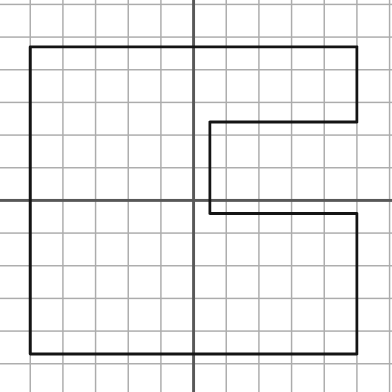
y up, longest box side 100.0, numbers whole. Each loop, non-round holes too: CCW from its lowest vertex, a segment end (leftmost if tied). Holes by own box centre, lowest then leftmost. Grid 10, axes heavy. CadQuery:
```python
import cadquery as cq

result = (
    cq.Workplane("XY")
    .moveTo(-50.0, -47.0)
    .lineTo(50.0, -47.0)
    .lineTo(50.0, -4.0)
    .lineTo(5.0, -4.0)
    .lineTo(5.0, 24.0)
    .lineTo(50.0, 24.0)
    .lineTo(50.0, 47.0)
    .lineTo(-50.0, 47.0)
    .close()
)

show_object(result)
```